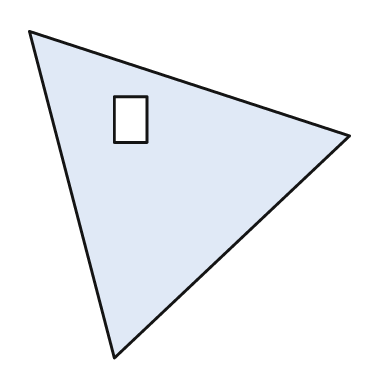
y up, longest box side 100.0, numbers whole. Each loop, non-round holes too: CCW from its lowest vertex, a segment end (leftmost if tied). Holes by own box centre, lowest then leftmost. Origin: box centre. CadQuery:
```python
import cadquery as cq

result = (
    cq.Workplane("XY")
    .moveTo(-23.0, -50.0)
    .lineTo(49.0, 18.0)
    .lineTo(-49.0, 50.0)
    .close()
    .moveTo(-23.0, 16.0)
    .lineTo(-13.0, 16.0)
    .lineTo(-13.0, 30.0)
    .lineTo(-23.0, 30.0)
    .close()
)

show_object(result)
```